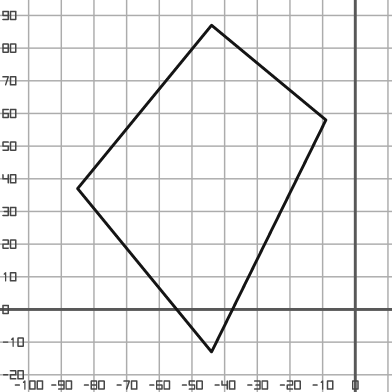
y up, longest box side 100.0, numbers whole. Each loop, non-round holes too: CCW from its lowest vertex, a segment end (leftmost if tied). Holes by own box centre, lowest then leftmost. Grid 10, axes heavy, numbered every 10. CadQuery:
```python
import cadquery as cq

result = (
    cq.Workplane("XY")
    .moveTo(-44.0, -13.0)
    .lineTo(-9.0, 58.0)
    .lineTo(-44.0, 87.0)
    .lineTo(-85.0, 37.0)
    .close()
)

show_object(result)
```